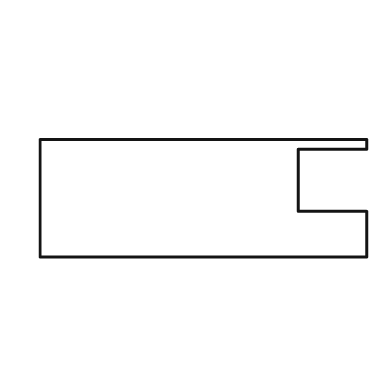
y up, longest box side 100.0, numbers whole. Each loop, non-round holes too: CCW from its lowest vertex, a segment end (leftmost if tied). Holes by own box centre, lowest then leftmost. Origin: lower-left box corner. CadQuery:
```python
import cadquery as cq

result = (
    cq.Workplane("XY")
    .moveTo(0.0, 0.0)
    .lineTo(100.0, 0.0)
    .lineTo(100.0, 14.0)
    .lineTo(79.0, 14.0)
    .lineTo(79.0, 33.0)
    .lineTo(100.0, 33.0)
    .lineTo(100.0, 36.0)
    .lineTo(0.0, 36.0)
    .close()
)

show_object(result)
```